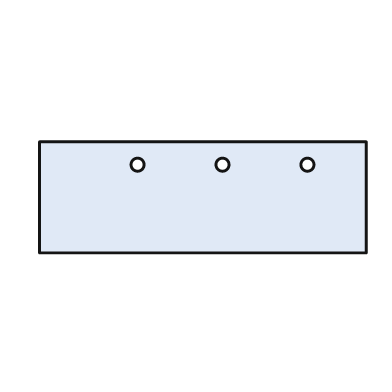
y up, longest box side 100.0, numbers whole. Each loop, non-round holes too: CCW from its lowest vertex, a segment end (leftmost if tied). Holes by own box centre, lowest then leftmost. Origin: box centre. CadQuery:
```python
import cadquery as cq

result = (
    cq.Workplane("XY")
    .moveTo(-50.0, -17.0)
    .lineTo(50.0, -17.0)
    .lineTo(50.0, 17.0)
    .lineTo(-50.0, 17.0)
    .close()
    .moveTo(-20.0, 10.0)
    .circle(2.0)
    .moveTo(6.0, 10.0)
    .circle(2.0)
    .moveTo(32.0, 10.0)
    .circle(2.0)
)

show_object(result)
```